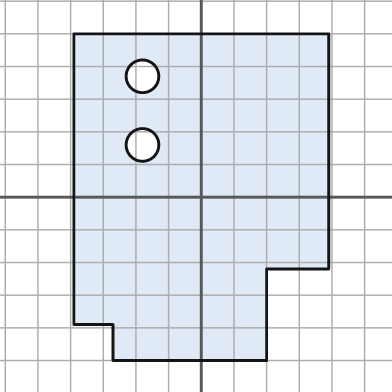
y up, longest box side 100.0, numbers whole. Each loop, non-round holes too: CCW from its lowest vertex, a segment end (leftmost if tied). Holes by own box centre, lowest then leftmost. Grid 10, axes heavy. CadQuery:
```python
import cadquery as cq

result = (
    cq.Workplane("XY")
    .moveTo(-27.0, -50.0)
    .lineTo(20.0, -50.0)
    .lineTo(20.0, -22.0)
    .lineTo(39.0, -22.0)
    .lineTo(39.0, 50.0)
    .lineTo(-39.0, 50.0)
    .lineTo(-39.0, -39.0)
    .lineTo(-27.0, -39.0)
    .close()
    .moveTo(-18.0, 16.0)
    .circle(5.0)
    .moveTo(-18.0, 37.0)
    .circle(5.0)
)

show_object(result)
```